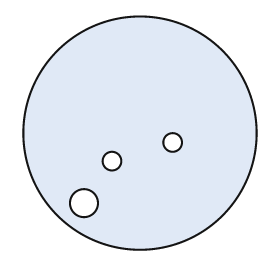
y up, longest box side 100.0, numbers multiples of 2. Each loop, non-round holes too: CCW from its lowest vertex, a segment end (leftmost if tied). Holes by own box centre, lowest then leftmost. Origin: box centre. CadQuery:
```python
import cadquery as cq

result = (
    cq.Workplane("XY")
    .moveTo(0.0, 0.0)
    .circle(50.0)
    .moveTo(-24.0, -30.0)
    .circle(6.0)
    .moveTo(-12.0, -12.0)
    .circle(4.0)
    .moveTo(14.0, -4.0)
    .circle(4.0)
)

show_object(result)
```